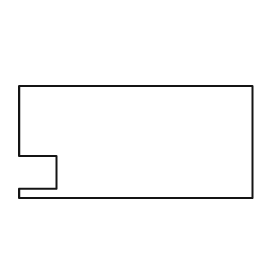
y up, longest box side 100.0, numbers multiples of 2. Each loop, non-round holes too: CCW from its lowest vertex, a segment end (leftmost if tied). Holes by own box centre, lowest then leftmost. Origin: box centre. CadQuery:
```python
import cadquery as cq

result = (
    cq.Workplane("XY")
    .moveTo(-50.0, -24.0)
    .lineTo(50.0, -24.0)
    .lineTo(50.0, 24.0)
    .lineTo(-50.0, 24.0)
    .lineTo(-50.0, -6.0)
    .lineTo(-34.0, -6.0)
    .lineTo(-34.0, -20.0)
    .lineTo(-50.0, -20.0)
    .close()
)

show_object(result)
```